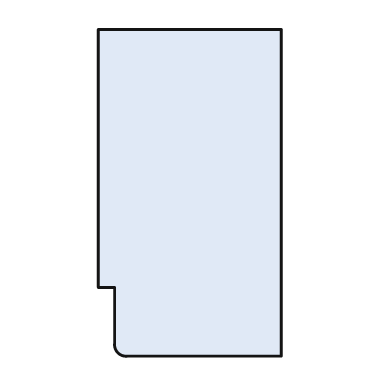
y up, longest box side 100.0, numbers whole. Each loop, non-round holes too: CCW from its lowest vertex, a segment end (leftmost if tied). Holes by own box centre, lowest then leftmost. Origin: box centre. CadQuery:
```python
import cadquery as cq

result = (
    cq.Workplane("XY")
    .moveTo(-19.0, -50.0)
    .lineTo(28.0, -50.0)
    .lineTo(28.0, 50.0)
    .lineTo(-28.0, 50.0)
    .lineTo(-28.0, -29.0)
    .lineTo(-23.0, -29.0)
    .lineTo(-23.0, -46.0)
    .threePointArc((-22.0, -49.0), (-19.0, -50.0))
    .close()
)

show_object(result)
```